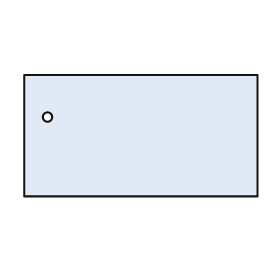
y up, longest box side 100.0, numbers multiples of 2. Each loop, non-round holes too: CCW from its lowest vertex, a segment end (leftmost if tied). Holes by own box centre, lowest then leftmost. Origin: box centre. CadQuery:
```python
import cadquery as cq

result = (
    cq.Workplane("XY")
    .moveTo(-50.0, -26.0)
    .lineTo(50.0, -26.0)
    .lineTo(50.0, 26.0)
    .lineTo(-50.0, 26.0)
    .close()
    .moveTo(-40.0, 8.0)
    .circle(2.0)
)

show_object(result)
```